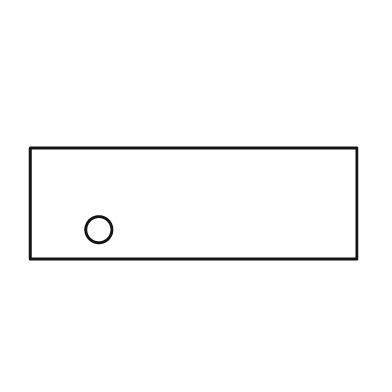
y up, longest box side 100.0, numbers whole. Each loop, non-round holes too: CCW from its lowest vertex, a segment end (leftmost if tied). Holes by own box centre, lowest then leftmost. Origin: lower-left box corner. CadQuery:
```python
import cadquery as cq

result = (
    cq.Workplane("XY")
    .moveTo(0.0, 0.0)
    .lineTo(100.0, 0.0)
    .lineTo(100.0, 34.0)
    .lineTo(0.0, 34.0)
    .close()
    .moveTo(21.0, 9.0)
    .circle(4.0)
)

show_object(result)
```